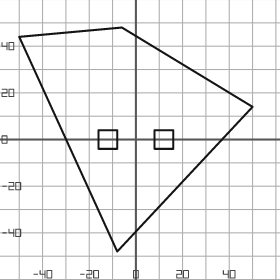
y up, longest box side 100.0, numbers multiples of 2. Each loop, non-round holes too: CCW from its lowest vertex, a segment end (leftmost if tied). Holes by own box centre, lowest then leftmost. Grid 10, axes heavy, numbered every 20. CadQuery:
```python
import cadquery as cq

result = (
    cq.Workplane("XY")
    .moveTo(-8.0, -48.0)
    .lineTo(50.0, 14.0)
    .lineTo(-6.0, 48.0)
    .lineTo(-50.0, 44.0)
    .close()
    .moveTo(-16.0, -4.0)
    .lineTo(-8.0, -4.0)
    .lineTo(-8.0, 4.0)
    .lineTo(-16.0, 4.0)
    .close()
    .moveTo(8.0, -4.0)
    .lineTo(16.0, -4.0)
    .lineTo(16.0, 4.0)
    .lineTo(8.0, 4.0)
    .close()
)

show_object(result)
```